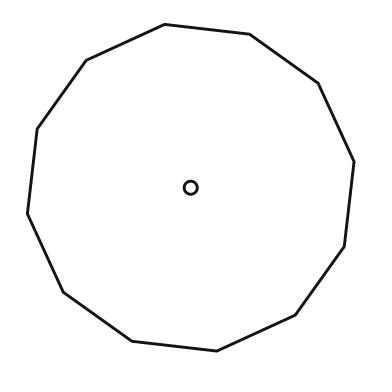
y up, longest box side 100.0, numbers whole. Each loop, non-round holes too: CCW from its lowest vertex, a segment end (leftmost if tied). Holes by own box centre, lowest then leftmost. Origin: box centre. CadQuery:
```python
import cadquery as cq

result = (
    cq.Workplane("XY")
    .moveTo(8.0, -50.0)
    .lineTo(32.0, -39.0)
    .lineTo(47.0, -18.0)
    .lineTo(50.0, 8.0)
    .lineTo(39.0, 32.0)
    .lineTo(18.0, 47.0)
    .lineTo(-8.0, 50.0)
    .lineTo(-32.0, 39.0)
    .lineTo(-47.0, 18.0)
    .lineTo(-50.0, -8.0)
    .lineTo(-39.0, -32.0)
    .lineTo(-18.0, -47.0)
    .close()
    .moveTo(0.0, 0.0)
    .circle(2.0)
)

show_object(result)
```